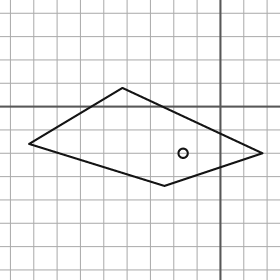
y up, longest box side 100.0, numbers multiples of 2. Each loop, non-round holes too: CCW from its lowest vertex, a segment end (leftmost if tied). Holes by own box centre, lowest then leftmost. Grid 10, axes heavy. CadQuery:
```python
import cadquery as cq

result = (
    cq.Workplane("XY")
    .moveTo(-24.0, -34.0)
    .lineTo(18.0, -20.0)
    .lineTo(-42.0, 8.0)
    .lineTo(-82.0, -16.0)
    .close()
    .moveTo(-16.0, -20.0)
    .circle(2.0)
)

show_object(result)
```